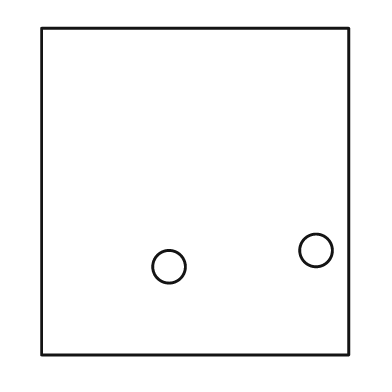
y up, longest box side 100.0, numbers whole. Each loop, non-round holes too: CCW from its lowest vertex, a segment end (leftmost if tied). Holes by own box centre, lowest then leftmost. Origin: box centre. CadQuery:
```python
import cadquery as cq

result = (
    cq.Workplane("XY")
    .moveTo(-47.0, -50.0)
    .lineTo(47.0, -50.0)
    .lineTo(47.0, 50.0)
    .lineTo(-47.0, 50.0)
    .close()
    .moveTo(-8.0, -23.0)
    .circle(5.0)
    .moveTo(37.0, -18.0)
    .circle(5.0)
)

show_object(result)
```